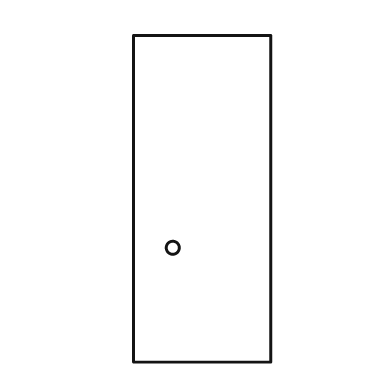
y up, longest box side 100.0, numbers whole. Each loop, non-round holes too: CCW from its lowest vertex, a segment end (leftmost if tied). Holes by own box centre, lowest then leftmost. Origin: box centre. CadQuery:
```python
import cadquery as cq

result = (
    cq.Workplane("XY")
    .moveTo(-21.0, -50.0)
    .lineTo(21.0, -50.0)
    .lineTo(21.0, 50.0)
    .lineTo(-21.0, 50.0)
    .close()
    .moveTo(-9.0, -15.0)
    .circle(2.0)
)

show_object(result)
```